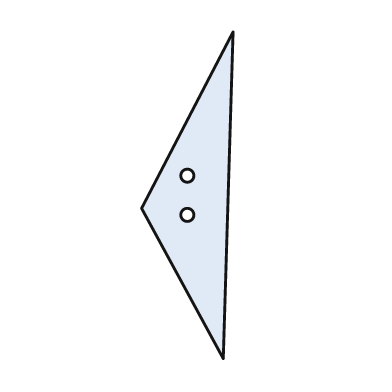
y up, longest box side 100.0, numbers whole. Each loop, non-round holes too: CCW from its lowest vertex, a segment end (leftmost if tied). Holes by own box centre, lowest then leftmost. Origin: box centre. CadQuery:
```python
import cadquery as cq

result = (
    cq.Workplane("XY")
    .moveTo(11.0, -50.0)
    .lineTo(14.0, 50.0)
    .lineTo(-14.0, -4.0)
    .close()
    .moveTo(0.0, -6.0)
    .circle(2.0)
    .moveTo(0.0, 6.0)
    .circle(2.0)
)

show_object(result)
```